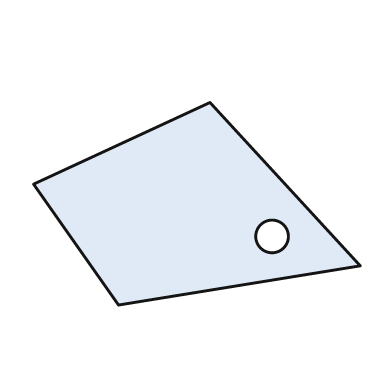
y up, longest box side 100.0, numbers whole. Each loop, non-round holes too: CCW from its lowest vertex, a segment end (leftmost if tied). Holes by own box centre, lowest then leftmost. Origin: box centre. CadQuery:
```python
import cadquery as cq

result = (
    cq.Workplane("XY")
    .moveTo(-24.0, -31.0)
    .lineTo(50.0, -19.0)
    .lineTo(4.0, 31.0)
    .lineTo(-50.0, 6.0)
    .close()
    .moveTo(23.0, -10.0)
    .circle(5.0)
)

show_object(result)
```